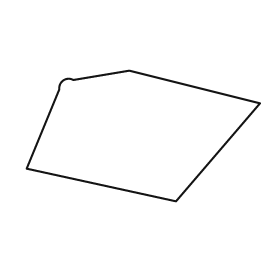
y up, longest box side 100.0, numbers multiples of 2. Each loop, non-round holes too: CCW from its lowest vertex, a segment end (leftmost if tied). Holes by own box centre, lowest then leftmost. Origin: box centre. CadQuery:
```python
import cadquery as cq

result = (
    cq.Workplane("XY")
    .moveTo(14.0, -28.0)
    .lineTo(50.0, 14.0)
    .lineTo(-6.0, 28.0)
    .lineTo(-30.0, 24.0)
    .threePointArc((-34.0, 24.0), (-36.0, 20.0))
    .lineTo(-50.0, -14.0)
    .close()
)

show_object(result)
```